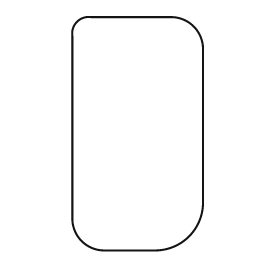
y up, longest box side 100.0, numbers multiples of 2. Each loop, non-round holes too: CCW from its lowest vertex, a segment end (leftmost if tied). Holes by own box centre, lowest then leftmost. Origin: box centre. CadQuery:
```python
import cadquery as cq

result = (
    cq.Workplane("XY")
    .moveTo(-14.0, -50.0)
    .lineTo(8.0, -50.0)
    .threePointArc((22.0, -44.0), (28.0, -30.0))
    .lineTo(28.0, 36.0)
    .threePointArc((24.0, 46.0), (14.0, 50.0))
    .lineTo(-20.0, 50.0)
    .threePointArc((-26.0, 48.0), (-28.0, 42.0))
    .lineTo(-28.0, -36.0)
    .threePointArc((-24.0, -46.0), (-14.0, -50.0))
    .close()
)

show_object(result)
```